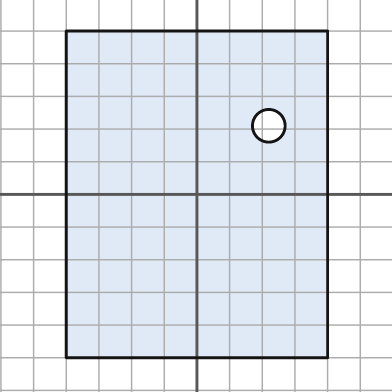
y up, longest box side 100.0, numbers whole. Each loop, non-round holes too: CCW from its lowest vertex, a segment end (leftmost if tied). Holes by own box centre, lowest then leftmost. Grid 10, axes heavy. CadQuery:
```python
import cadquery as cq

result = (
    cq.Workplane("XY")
    .moveTo(-40.0, -50.0)
    .lineTo(40.0, -50.0)
    .lineTo(40.0, 50.0)
    .lineTo(-40.0, 50.0)
    .close()
    .moveTo(22.0, 21.0)
    .circle(5.0)
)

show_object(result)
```